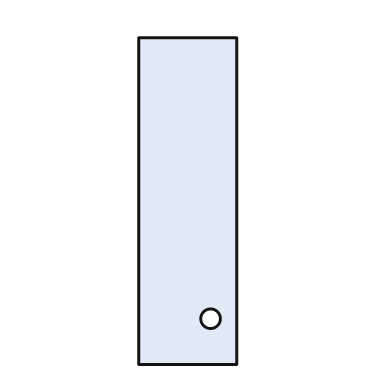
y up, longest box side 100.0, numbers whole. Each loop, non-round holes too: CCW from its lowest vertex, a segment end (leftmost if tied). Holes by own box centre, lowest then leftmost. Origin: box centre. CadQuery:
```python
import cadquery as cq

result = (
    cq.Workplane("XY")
    .moveTo(-15.0, -50.0)
    .lineTo(15.0, -50.0)
    .lineTo(15.0, 50.0)
    .lineTo(-15.0, 50.0)
    .close()
    .moveTo(7.0, -36.0)
    .circle(3.0)
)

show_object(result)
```